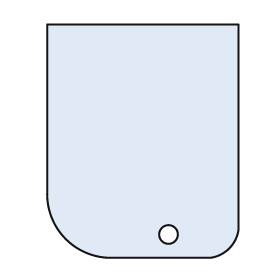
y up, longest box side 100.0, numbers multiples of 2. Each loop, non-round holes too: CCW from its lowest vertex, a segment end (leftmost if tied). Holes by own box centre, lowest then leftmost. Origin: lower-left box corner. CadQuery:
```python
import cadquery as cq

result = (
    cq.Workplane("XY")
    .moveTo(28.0, 0.0)
    .lineTo(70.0, 0.0)
    .threePointArc((78.0, 4.0), (82.0, 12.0))
    .lineTo(82.0, 100.0)
    .lineTo(0.0, 100.0)
    .lineTo(0.0, 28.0)
    .threePointArc((8.0, 8.0), (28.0, 0.0))
    .close()
    .moveTo(52.0, 10.0)
    .circle(4.0)
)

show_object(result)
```